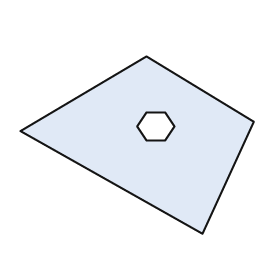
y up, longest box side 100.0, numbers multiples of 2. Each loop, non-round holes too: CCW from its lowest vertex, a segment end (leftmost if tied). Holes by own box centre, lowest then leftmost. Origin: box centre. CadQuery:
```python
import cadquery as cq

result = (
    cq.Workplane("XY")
    .moveTo(28.0, -38.0)
    .lineTo(50.0, 10.0)
    .lineTo(4.0, 38.0)
    .lineTo(-50.0, 6.0)
    .close()
    .moveTo(4.0, 2.0)
    .lineTo(12.0, 2.0)
    .lineTo(16.0, 8.0)
    .lineTo(12.0, 14.0)
    .lineTo(4.0, 14.0)
    .lineTo(0.0, 8.0)
    .close()
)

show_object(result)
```